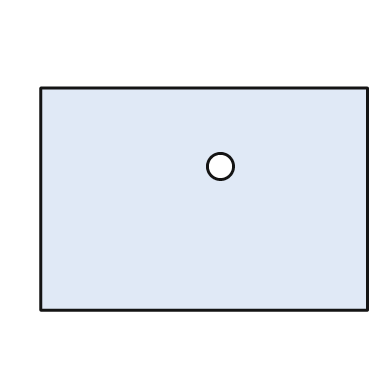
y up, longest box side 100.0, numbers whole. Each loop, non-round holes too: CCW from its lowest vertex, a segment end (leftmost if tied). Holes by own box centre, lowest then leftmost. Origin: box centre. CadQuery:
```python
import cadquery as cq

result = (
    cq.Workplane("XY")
    .moveTo(-50.0, -34.0)
    .lineTo(50.0, -34.0)
    .lineTo(50.0, 34.0)
    .lineTo(-50.0, 34.0)
    .close()
    .moveTo(5.0, 10.0)
    .circle(4.0)
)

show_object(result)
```